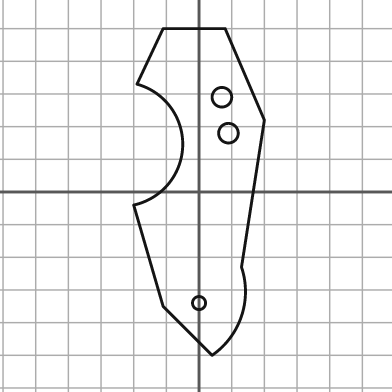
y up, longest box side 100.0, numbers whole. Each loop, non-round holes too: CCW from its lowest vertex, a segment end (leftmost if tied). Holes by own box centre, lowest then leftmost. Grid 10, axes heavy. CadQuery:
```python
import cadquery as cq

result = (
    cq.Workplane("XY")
    .moveTo(4.0, -50.0)
    .threePointArc((13.0, -38.0), (13.0, -23.0))
    .lineTo(20.0, 22.0)
    .lineTo(8.0, 50.0)
    .lineTo(-11.0, 50.0)
    .lineTo(-19.0, 33.0)
    .threePointArc((-5.0, 14.0), (-20.0, -4.0))
    .lineTo(-11.0, -35.0)
    .close()
    .moveTo(0.0, -34.0)
    .circle(2.0)
    .moveTo(9.0, 18.0)
    .circle(3.0)
    .moveTo(7.0, 29.0)
    .circle(3.0)
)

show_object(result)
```